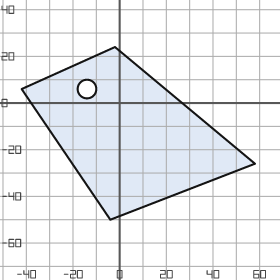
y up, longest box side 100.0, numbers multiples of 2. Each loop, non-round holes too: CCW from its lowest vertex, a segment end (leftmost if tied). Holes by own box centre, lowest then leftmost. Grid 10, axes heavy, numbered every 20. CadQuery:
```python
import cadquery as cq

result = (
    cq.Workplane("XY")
    .moveTo(-4.0, -50.0)
    .lineTo(58.0, -26.0)
    .lineTo(-2.0, 24.0)
    .lineTo(-42.0, 6.0)
    .close()
    .moveTo(-14.0, 6.0)
    .circle(4.0)
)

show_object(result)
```